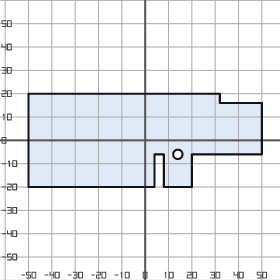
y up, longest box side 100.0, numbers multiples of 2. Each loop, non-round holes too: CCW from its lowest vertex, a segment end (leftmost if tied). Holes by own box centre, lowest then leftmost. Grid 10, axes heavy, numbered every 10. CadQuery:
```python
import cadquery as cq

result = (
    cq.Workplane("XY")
    .moveTo(-50.0, -20.0)
    .lineTo(4.0, -20.0)
    .lineTo(4.0, -6.0)
    .lineTo(8.0, -6.0)
    .lineTo(8.0, -20.0)
    .lineTo(20.0, -20.0)
    .lineTo(20.0, -6.0)
    .lineTo(50.0, -6.0)
    .lineTo(50.0, 16.0)
    .lineTo(32.0, 16.0)
    .lineTo(32.0, 20.0)
    .lineTo(-50.0, 20.0)
    .close()
    .moveTo(14.0, -6.0)
    .circle(2.0)
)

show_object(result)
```